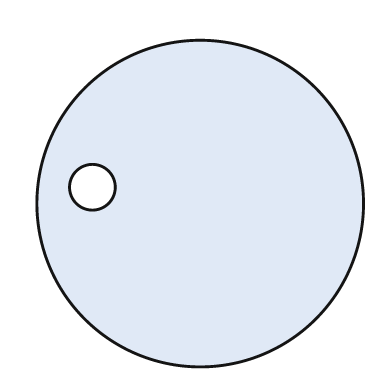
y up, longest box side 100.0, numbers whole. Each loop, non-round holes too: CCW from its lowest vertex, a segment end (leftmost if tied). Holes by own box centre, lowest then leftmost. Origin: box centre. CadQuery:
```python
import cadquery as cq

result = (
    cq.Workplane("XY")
    .moveTo(0.0, 0.0)
    .circle(50.0)
    .moveTo(-33.0, 5.0)
    .circle(7.0)
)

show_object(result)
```